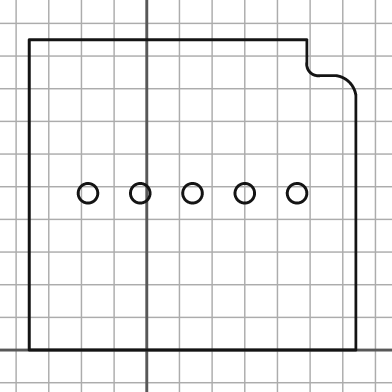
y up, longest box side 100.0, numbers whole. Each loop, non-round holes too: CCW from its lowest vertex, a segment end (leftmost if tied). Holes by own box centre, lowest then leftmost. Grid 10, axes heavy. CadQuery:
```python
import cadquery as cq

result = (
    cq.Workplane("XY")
    .moveTo(-36.0, 0.0)
    .lineTo(64.0, 0.0)
    .lineTo(64.0, 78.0)
    .threePointArc((62.0, 82.0), (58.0, 84.0))
    .lineTo(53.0, 84.0)
    .threePointArc((50.0, 85.0), (49.0, 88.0))
    .lineTo(49.0, 95.0)
    .lineTo(-36.0, 95.0)
    .close()
    .moveTo(-18.0, 48.0)
    .circle(3.0)
    .moveTo(-2.0, 48.0)
    .circle(3.0)
    .moveTo(14.0, 48.0)
    .circle(3.0)
    .moveTo(30.0, 48.0)
    .circle(3.0)
    .moveTo(46.0, 48.0)
    .circle(3.0)
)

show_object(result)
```